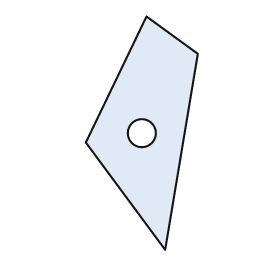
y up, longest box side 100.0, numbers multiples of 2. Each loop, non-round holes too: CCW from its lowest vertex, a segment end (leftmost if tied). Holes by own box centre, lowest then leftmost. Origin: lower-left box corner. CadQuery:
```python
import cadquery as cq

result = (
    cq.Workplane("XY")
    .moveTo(34.0, 0.0)
    .lineTo(48.0, 84.0)
    .lineTo(26.0, 100.0)
    .lineTo(0.0, 46.0)
    .close()
    .moveTo(24.0, 50.0)
    .circle(6.0)
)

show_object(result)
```